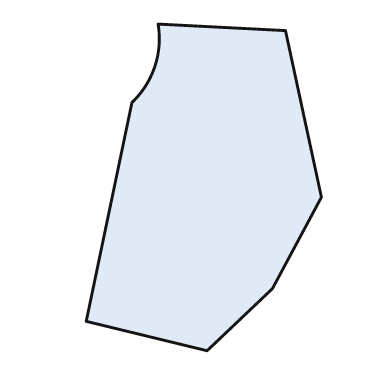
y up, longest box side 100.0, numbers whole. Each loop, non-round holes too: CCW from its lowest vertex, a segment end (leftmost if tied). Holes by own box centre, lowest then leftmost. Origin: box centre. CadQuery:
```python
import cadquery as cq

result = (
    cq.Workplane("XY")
    .moveTo(1.0, -50.0)
    .lineTo(21.0, -31.0)
    .lineTo(36.0, -3.0)
    .lineTo(25.0, 48.0)
    .lineTo(-14.0, 50.0)
    .threePointArc((-15.0, 37.0), (-22.0, 26.0))
    .lineTo(-36.0, -41.0)
    .close()
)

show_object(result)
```